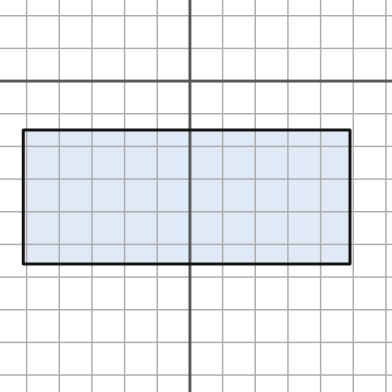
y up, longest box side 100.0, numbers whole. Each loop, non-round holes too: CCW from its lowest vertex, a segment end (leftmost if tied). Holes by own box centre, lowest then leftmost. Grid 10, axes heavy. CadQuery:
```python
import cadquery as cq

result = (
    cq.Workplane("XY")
    .moveTo(-51.0, -56.0)
    .lineTo(49.0, -56.0)
    .lineTo(49.0, -15.0)
    .lineTo(-51.0, -15.0)
    .close()
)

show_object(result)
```